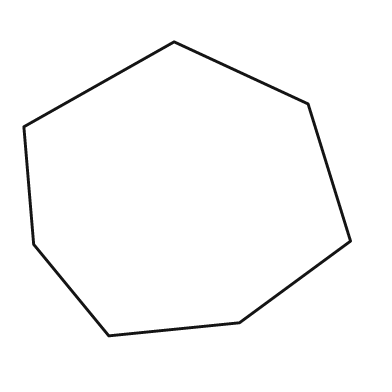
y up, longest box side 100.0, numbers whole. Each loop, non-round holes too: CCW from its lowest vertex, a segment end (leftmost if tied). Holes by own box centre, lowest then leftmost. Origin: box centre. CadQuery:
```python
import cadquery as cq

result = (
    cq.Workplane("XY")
    .moveTo(-24.0, -45.0)
    .lineTo(16.0, -41.0)
    .lineTo(50.0, -16.0)
    .lineTo(37.0, 26.0)
    .lineTo(-4.0, 45.0)
    .lineTo(-50.0, 19.0)
    .lineTo(-47.0, -17.0)
    .close()
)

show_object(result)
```